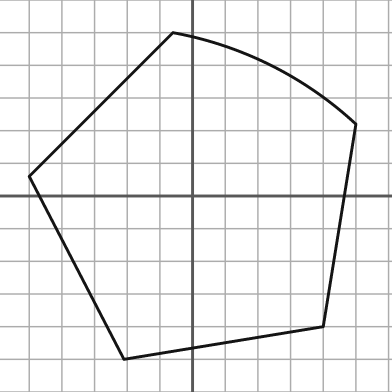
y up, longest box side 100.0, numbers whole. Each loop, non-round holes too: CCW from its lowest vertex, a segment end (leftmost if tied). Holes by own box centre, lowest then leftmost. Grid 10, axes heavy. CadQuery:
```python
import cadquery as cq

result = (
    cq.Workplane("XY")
    .moveTo(-21.0, -50.0)
    .lineTo(40.0, -40.0)
    .lineTo(50.0, 22.0)
    .threePointArc((24.0, 40.0), (-6.0, 50.0))
    .lineTo(-50.0, 6.0)
    .close()
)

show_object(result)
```